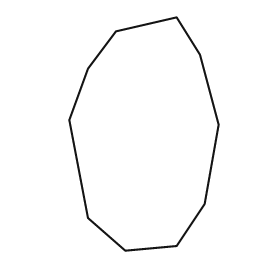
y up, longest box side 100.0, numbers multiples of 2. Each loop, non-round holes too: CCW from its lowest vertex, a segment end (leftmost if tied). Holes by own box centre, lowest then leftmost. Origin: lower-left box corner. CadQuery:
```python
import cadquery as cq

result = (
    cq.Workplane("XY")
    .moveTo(24.0, 0.0)
    .lineTo(46.0, 2.0)
    .lineTo(58.0, 20.0)
    .lineTo(64.0, 54.0)
    .lineTo(56.0, 84.0)
    .lineTo(46.0, 100.0)
    .lineTo(20.0, 94.0)
    .lineTo(8.0, 78.0)
    .lineTo(0.0, 56.0)
    .lineTo(8.0, 14.0)
    .close()
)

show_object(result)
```